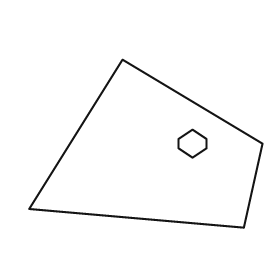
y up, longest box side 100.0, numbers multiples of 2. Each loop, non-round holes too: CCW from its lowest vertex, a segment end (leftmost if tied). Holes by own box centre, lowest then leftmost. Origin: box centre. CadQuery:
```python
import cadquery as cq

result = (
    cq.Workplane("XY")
    .moveTo(42.0, -36.0)
    .lineTo(50.0, 0.0)
    .lineTo(-10.0, 36.0)
    .lineTo(-50.0, -28.0)
    .close()
    .moveTo(20.0, -6.0)
    .lineTo(26.0, -2.0)
    .lineTo(26.0, 2.0)
    .lineTo(20.0, 6.0)
    .lineTo(14.0, 2.0)
    .lineTo(14.0, -2.0)
    .close()
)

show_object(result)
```